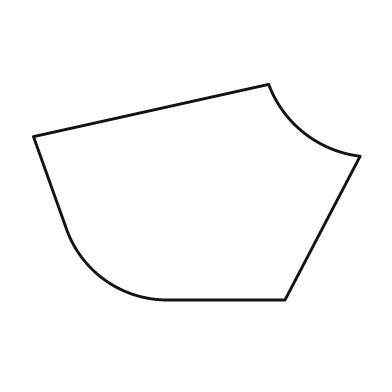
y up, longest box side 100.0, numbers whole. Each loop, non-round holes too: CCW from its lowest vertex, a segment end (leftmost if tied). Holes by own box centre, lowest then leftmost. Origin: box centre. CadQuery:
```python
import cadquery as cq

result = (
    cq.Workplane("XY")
    .moveTo(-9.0, -33.0)
    .lineTo(27.0, -33.0)
    .lineTo(50.0, 11.0)
    .threePointArc((33.0, 18.0), (22.0, 33.0))
    .lineTo(-50.0, 17.0)
    .lineTo(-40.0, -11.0)
    .threePointArc((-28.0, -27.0), (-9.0, -33.0))
    .close()
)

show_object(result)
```